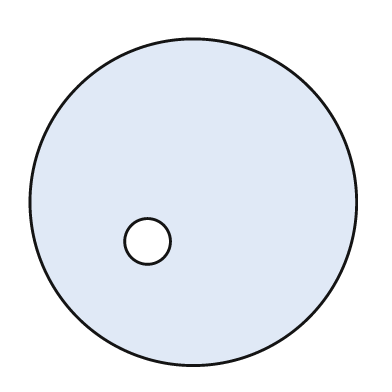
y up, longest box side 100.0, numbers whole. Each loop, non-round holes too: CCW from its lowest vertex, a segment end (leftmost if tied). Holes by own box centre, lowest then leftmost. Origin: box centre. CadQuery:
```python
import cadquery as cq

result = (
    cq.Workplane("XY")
    .moveTo(0.0, 0.0)
    .circle(50.0)
    .moveTo(-14.0, -12.0)
    .circle(7.0)
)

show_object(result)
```